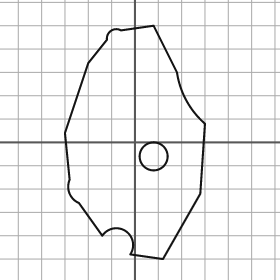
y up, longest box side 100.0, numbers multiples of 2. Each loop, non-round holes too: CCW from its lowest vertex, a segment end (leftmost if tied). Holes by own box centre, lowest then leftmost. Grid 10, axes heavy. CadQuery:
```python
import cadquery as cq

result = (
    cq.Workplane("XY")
    .moveTo(12.0, -50.0)
    .lineTo(28.0, -22.0)
    .lineTo(30.0, 8.0)
    .threePointArc((22.0, 18.0), (18.0, 30.0))
    .lineTo(8.0, 50.0)
    .lineTo(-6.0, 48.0)
    .threePointArc((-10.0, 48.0), (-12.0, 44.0))
    .lineTo(-20.0, 34.0)
    .lineTo(-30.0, 4.0)
    .lineTo(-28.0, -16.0)
    .threePointArc((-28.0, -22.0), (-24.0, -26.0))
    .lineTo(-14.0, -40.0)
    .threePointArc((-4.0, -38.0), (-2.0, -48.0))
    .close()
    .moveTo(8.0, -6.0)
    .circle(6.0)
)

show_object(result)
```